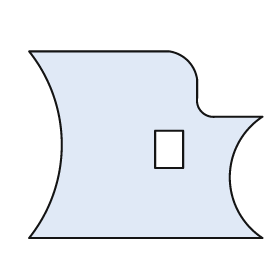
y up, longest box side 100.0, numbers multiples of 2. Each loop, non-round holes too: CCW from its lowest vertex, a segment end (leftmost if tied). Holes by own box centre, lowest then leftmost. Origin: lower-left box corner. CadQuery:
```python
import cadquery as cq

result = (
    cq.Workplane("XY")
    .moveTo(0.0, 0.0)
    .lineTo(100.0, 0.0)
    .threePointArc((86.0, 26.0), (100.0, 52.0))
    .lineTo(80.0, 52.0)
    .threePointArc((74.0, 54.0), (72.0, 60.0))
    .lineTo(72.0, 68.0)
    .threePointArc((68.0, 76.0), (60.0, 80.0))
    .lineTo(0.0, 80.0)
    .threePointArc((14.0, 40.0), (0.0, 0.0))
    .close()
    .moveTo(54.0, 30.0)
    .lineTo(66.0, 30.0)
    .lineTo(66.0, 46.0)
    .lineTo(54.0, 46.0)
    .close()
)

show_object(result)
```